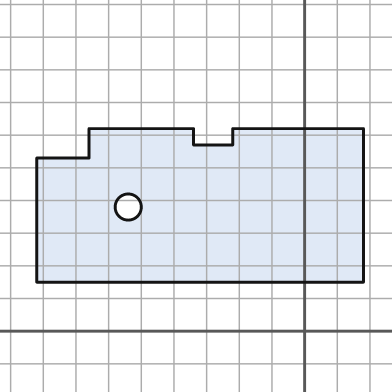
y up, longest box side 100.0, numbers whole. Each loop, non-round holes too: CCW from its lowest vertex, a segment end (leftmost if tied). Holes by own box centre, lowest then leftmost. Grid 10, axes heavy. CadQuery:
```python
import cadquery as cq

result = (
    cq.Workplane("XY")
    .moveTo(-82.0, 15.0)
    .lineTo(18.0, 15.0)
    .lineTo(18.0, 62.0)
    .lineTo(-22.0, 62.0)
    .lineTo(-22.0, 57.0)
    .lineTo(-34.0, 57.0)
    .lineTo(-34.0, 62.0)
    .lineTo(-66.0, 62.0)
    .lineTo(-66.0, 53.0)
    .lineTo(-82.0, 53.0)
    .close()
    .moveTo(-54.0, 38.0)
    .circle(4.0)
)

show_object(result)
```